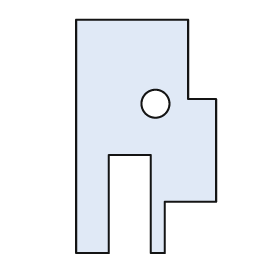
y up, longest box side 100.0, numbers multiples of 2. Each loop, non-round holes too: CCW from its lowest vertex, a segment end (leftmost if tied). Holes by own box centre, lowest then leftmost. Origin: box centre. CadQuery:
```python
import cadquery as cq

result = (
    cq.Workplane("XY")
    .moveTo(-30.0, -50.0)
    .lineTo(-16.0, -50.0)
    .lineTo(-16.0, -8.0)
    .lineTo(2.0, -8.0)
    .lineTo(2.0, -50.0)
    .lineTo(8.0, -50.0)
    .lineTo(8.0, -28.0)
    .lineTo(30.0, -28.0)
    .lineTo(30.0, 16.0)
    .lineTo(18.0, 16.0)
    .lineTo(18.0, 50.0)
    .lineTo(-30.0, 50.0)
    .close()
    .moveTo(4.0, 14.0)
    .circle(6.0)
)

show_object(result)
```